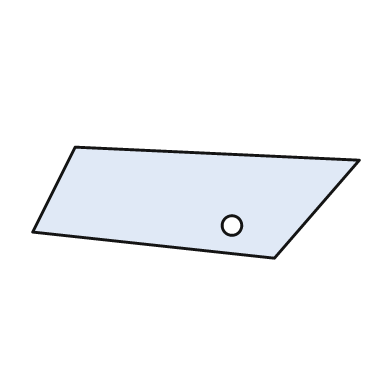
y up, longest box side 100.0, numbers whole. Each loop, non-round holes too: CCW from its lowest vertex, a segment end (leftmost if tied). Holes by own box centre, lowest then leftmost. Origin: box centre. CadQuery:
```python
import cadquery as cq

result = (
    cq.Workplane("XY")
    .moveTo(24.0, -17.0)
    .lineTo(50.0, 13.0)
    .lineTo(-37.0, 17.0)
    .lineTo(-50.0, -9.0)
    .close()
    .moveTo(11.0, -7.0)
    .circle(3.0)
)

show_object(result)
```